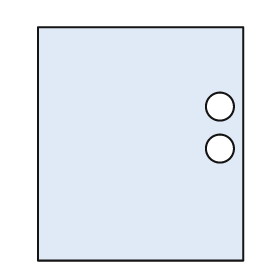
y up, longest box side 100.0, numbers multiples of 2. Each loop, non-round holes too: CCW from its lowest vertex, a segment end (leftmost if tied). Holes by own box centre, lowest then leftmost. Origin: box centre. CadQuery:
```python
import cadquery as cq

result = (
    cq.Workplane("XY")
    .moveTo(-44.0, -50.0)
    .lineTo(44.0, -50.0)
    .lineTo(44.0, 50.0)
    .lineTo(-44.0, 50.0)
    .close()
    .moveTo(34.0, -2.0)
    .circle(6.0)
    .moveTo(34.0, 16.0)
    .circle(6.0)
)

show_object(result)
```